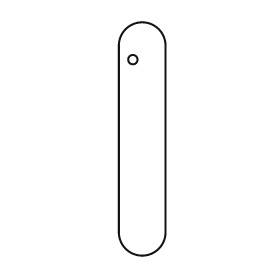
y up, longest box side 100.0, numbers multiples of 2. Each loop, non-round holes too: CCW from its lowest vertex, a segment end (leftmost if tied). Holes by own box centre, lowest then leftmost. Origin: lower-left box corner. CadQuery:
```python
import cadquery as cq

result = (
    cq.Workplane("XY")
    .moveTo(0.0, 10.0)
    .threePointArc((10.0, 0.0), (20.0, 10.0))
    .lineTo(20.0, 90.0)
    .threePointArc((10.0, 100.0), (0.0, 90.0))
    .close()
    .moveTo(6.0, 84.0)
    .circle(2.0)
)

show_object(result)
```